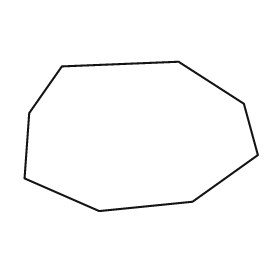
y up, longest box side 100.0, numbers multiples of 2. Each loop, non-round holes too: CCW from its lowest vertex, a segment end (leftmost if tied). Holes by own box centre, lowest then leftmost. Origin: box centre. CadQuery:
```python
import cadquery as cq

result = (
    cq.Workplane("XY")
    .moveTo(-18.0, -32.0)
    .lineTo(22.0, -28.0)
    .lineTo(50.0, -8.0)
    .lineTo(44.0, 14.0)
    .lineTo(16.0, 32.0)
    .lineTo(-34.0, 30.0)
    .lineTo(-48.0, 10.0)
    .lineTo(-50.0, -18.0)
    .close()
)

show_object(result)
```